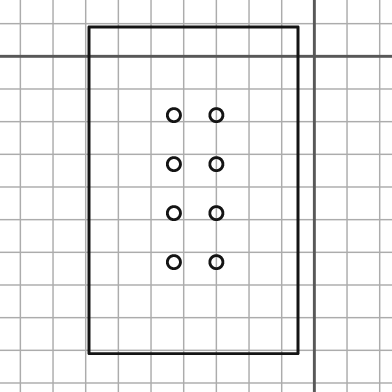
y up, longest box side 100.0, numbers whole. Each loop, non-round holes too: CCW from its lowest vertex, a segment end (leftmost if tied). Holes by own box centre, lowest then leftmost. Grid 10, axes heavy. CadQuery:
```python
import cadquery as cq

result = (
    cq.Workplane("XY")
    .moveTo(-69.0, -91.0)
    .lineTo(-5.0, -91.0)
    .lineTo(-5.0, 9.0)
    .lineTo(-69.0, 9.0)
    .close()
    .moveTo(-43.0, -63.0)
    .circle(2.0)
    .moveTo(-30.0, -63.0)
    .circle(2.0)
    .moveTo(-43.0, -48.0)
    .circle(2.0)
    .moveTo(-30.0, -48.0)
    .circle(2.0)
    .moveTo(-43.0, -33.0)
    .circle(2.0)
    .moveTo(-30.0, -33.0)
    .circle(2.0)
    .moveTo(-43.0, -18.0)
    .circle(2.0)
    .moveTo(-30.0, -18.0)
    .circle(2.0)
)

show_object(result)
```